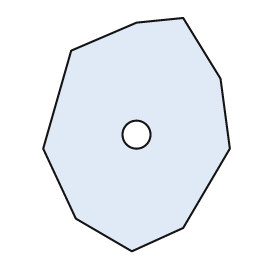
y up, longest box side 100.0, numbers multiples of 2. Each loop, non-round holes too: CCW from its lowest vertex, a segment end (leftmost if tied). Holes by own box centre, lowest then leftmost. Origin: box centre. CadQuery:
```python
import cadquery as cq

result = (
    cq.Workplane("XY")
    .moveTo(-2.0, -50.0)
    .lineTo(20.0, -40.0)
    .lineTo(40.0, -6.0)
    .lineTo(36.0, 24.0)
    .lineTo(20.0, 50.0)
    .lineTo(0.0, 48.0)
    .lineTo(-28.0, 36.0)
    .lineTo(-40.0, -6.0)
    .lineTo(-26.0, -36.0)
    .close()
    .moveTo(0.0, 0.0)
    .circle(6.0)
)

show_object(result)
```